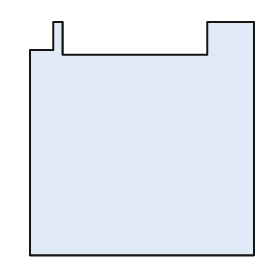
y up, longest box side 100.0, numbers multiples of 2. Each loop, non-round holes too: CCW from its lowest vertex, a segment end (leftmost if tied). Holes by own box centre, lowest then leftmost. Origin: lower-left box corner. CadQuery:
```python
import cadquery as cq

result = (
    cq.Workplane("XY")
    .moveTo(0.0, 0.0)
    .lineTo(96.0, 0.0)
    .lineTo(96.0, 100.0)
    .lineTo(76.0, 100.0)
    .lineTo(76.0, 86.0)
    .lineTo(14.0, 86.0)
    .lineTo(14.0, 100.0)
    .lineTo(10.0, 100.0)
    .lineTo(10.0, 88.0)
    .lineTo(0.0, 88.0)
    .close()
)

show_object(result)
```